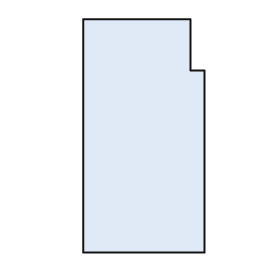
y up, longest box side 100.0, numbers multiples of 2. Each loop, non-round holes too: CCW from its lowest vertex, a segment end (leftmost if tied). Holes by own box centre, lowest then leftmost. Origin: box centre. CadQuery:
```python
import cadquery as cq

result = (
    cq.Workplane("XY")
    .moveTo(-26.0, -50.0)
    .lineTo(26.0, -50.0)
    .lineTo(26.0, 28.0)
    .lineTo(20.0, 28.0)
    .lineTo(20.0, 50.0)
    .lineTo(-26.0, 50.0)
    .close()
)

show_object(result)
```